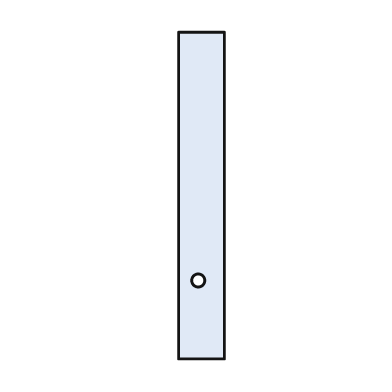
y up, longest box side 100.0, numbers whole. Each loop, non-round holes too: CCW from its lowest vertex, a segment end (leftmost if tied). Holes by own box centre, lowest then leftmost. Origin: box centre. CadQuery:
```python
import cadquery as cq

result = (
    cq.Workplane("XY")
    .moveTo(-7.0, -50.0)
    .lineTo(7.0, -50.0)
    .lineTo(7.0, 50.0)
    .lineTo(-7.0, 50.0)
    .close()
    .moveTo(-1.0, -26.0)
    .circle(2.0)
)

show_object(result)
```